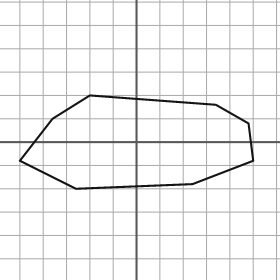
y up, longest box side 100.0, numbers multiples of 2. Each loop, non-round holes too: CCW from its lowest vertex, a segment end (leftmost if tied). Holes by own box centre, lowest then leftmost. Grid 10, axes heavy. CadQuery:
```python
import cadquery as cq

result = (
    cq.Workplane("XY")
    .moveTo(-26.0, -20.0)
    .lineTo(24.0, -18.0)
    .lineTo(50.0, -8.0)
    .lineTo(48.0, 8.0)
    .lineTo(34.0, 16.0)
    .lineTo(-20.0, 20.0)
    .lineTo(-36.0, 10.0)
    .lineTo(-50.0, -8.0)
    .close()
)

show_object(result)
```